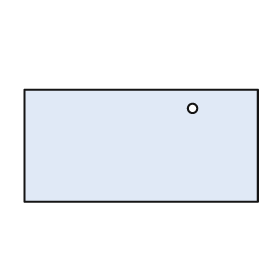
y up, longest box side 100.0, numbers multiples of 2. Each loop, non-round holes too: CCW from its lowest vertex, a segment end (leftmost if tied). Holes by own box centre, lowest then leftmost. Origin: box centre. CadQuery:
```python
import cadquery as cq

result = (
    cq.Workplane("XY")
    .moveTo(-50.0, -24.0)
    .lineTo(50.0, -24.0)
    .lineTo(50.0, 24.0)
    .lineTo(-50.0, 24.0)
    .close()
    .moveTo(22.0, 16.0)
    .circle(2.0)
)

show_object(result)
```